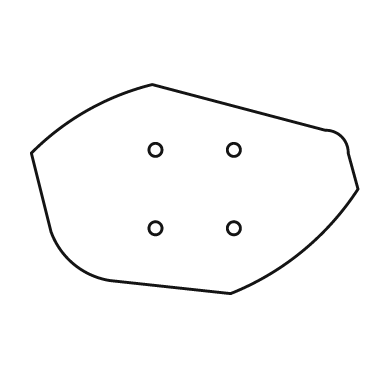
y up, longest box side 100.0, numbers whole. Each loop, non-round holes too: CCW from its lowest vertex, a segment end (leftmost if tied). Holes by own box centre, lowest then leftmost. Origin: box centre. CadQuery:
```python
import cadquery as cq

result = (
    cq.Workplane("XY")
    .moveTo(11.0, -32.0)
    .threePointArc((33.0, -19.0), (50.0, 0.0))
    .lineTo(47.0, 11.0)
    .threePointArc((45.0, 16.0), (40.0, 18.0))
    .lineTo(-13.0, 32.0)
    .threePointArc((-33.0, 24.0), (-50.0, 11.0))
    .lineTo(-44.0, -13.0)
    .threePointArc((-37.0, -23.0), (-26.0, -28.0))
    .close()
    .moveTo(-12.0, -12.0)
    .circle(2.0)
    .moveTo(12.0, -12.0)
    .circle(2.0)
    .moveTo(-12.0, 12.0)
    .circle(2.0)
    .moveTo(12.0, 12.0)
    .circle(2.0)
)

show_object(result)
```